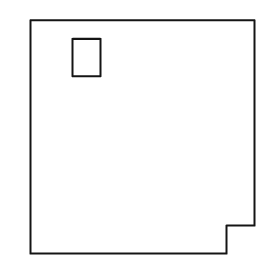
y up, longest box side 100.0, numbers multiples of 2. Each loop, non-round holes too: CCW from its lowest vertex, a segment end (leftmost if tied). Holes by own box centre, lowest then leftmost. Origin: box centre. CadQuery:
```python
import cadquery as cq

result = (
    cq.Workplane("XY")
    .moveTo(-48.0, -50.0)
    .lineTo(36.0, -50.0)
    .lineTo(36.0, -38.0)
    .lineTo(48.0, -38.0)
    .lineTo(48.0, 50.0)
    .lineTo(-48.0, 50.0)
    .close()
    .moveTo(-30.0, 26.0)
    .lineTo(-18.0, 26.0)
    .lineTo(-18.0, 42.0)
    .lineTo(-30.0, 42.0)
    .close()
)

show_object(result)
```